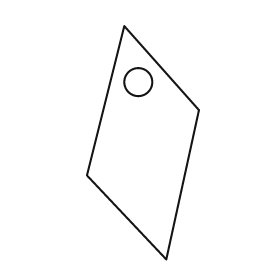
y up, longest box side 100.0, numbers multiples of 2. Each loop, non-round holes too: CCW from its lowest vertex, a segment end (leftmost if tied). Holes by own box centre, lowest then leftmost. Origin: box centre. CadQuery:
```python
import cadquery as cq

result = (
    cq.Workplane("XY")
    .moveTo(10.0, -50.0)
    .lineTo(24.0, 14.0)
    .lineTo(-8.0, 50.0)
    .lineTo(-24.0, -14.0)
    .close()
    .moveTo(-2.0, 26.0)
    .circle(6.0)
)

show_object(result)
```